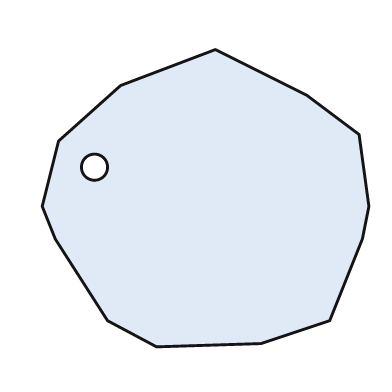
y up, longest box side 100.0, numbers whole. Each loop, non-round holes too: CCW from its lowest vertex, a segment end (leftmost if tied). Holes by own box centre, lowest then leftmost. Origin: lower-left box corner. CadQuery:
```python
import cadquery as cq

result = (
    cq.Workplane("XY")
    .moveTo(35.0, 0.0)
    .lineTo(67.0, 1.0)
    .lineTo(88.0, 8.0)
    .lineTo(98.0, 33.0)
    .lineTo(100.0, 43.0)
    .lineTo(97.0, 65.0)
    .lineTo(81.0, 77.0)
    .lineTo(53.0, 91.0)
    .lineTo(24.0, 80.0)
    .lineTo(5.0, 63.0)
    .lineTo(0.0, 43.0)
    .lineTo(4.0, 33.0)
    .lineTo(20.0, 8.0)
    .close()
    .moveTo(16.0, 55.0)
    .circle(4.0)
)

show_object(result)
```